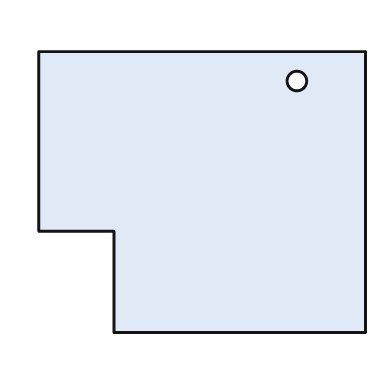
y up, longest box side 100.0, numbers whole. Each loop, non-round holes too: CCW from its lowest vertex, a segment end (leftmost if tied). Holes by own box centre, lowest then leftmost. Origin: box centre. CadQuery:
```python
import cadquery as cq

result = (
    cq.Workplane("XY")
    .moveTo(-27.0, -43.0)
    .lineTo(50.0, -43.0)
    .lineTo(50.0, 43.0)
    .lineTo(-50.0, 43.0)
    .lineTo(-50.0, -12.0)
    .lineTo(-27.0, -12.0)
    .close()
    .moveTo(29.0, 34.0)
    .circle(3.0)
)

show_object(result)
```